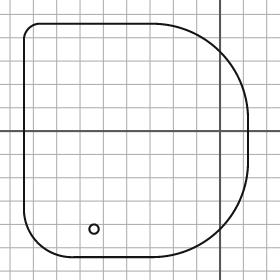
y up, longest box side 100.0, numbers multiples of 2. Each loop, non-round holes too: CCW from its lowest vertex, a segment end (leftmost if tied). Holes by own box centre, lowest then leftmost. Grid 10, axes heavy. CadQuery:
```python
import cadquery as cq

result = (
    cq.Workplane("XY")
    .moveTo(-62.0, -54.0)
    .lineTo(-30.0, -54.0)
    .threePointArc((0.0, -42.0), (12.0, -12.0))
    .lineTo(12.0, 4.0)
    .threePointArc((0.0, 34.0), (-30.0, 46.0))
    .lineTo(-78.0, 46.0)
    .threePointArc((-82.0, 44.0), (-84.0, 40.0))
    .lineTo(-84.0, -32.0)
    .threePointArc((-78.0, -48.0), (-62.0, -54.0))
    .close()
    .moveTo(-54.0, -42.0)
    .circle(2.0)
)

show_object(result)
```